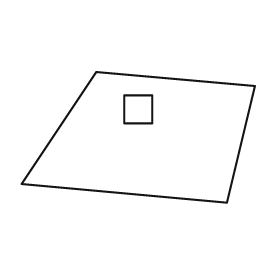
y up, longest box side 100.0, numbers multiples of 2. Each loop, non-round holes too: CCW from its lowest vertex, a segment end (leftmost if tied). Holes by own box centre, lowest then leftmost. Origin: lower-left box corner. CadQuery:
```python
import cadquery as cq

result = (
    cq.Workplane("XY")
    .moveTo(88.0, 0.0)
    .lineTo(100.0, 50.0)
    .lineTo(32.0, 56.0)
    .lineTo(0.0, 8.0)
    .close()
    .moveTo(44.0, 34.0)
    .lineTo(56.0, 34.0)
    .lineTo(56.0, 46.0)
    .lineTo(44.0, 46.0)
    .close()
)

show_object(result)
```